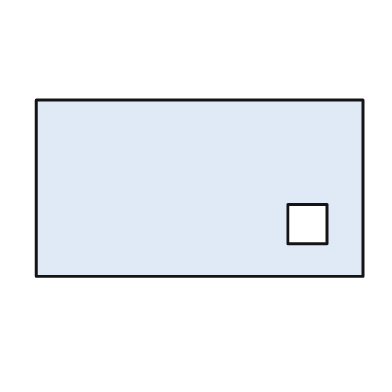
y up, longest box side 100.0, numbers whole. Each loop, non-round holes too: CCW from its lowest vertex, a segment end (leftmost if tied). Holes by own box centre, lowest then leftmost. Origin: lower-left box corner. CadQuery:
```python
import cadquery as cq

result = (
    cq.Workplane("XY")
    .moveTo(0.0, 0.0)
    .lineTo(100.0, 0.0)
    .lineTo(100.0, 54.0)
    .lineTo(0.0, 54.0)
    .close()
    .moveTo(77.0, 10.0)
    .lineTo(89.0, 10.0)
    .lineTo(89.0, 22.0)
    .lineTo(77.0, 22.0)
    .close()
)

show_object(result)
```